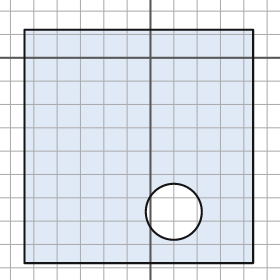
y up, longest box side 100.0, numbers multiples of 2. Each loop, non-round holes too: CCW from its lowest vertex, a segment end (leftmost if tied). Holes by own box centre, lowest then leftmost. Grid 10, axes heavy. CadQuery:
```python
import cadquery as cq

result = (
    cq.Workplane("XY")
    .moveTo(-54.0, -88.0)
    .lineTo(44.0, -88.0)
    .lineTo(44.0, 12.0)
    .lineTo(-54.0, 12.0)
    .close()
    .moveTo(10.0, -66.0)
    .circle(12.0)
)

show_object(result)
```